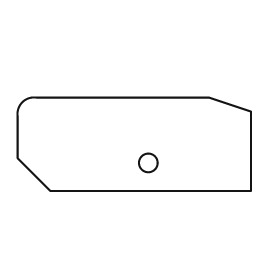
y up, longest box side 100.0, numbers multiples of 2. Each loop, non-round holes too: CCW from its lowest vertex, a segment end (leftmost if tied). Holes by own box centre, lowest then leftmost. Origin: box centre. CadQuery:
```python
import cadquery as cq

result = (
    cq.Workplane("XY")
    .moveTo(-36.0, -20.0)
    .lineTo(50.0, -20.0)
    .lineTo(50.0, 14.0)
    .lineTo(32.0, 20.0)
    .lineTo(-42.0, 20.0)
    .threePointArc((-48.0, 18.0), (-50.0, 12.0))
    .lineTo(-50.0, -6.0)
    .close()
    .moveTo(6.0, -8.0)
    .circle(4.0)
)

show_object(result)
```